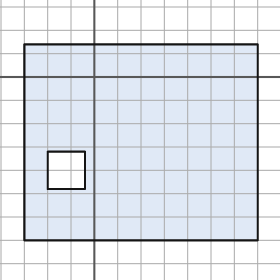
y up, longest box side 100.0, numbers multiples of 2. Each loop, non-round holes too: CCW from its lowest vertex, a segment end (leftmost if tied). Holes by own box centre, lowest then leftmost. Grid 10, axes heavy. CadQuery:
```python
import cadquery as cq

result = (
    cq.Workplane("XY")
    .moveTo(-30.0, -70.0)
    .lineTo(70.0, -70.0)
    .lineTo(70.0, 14.0)
    .lineTo(-30.0, 14.0)
    .close()
    .moveTo(-20.0, -48.0)
    .lineTo(-4.0, -48.0)
    .lineTo(-4.0, -32.0)
    .lineTo(-20.0, -32.0)
    .close()
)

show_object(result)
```